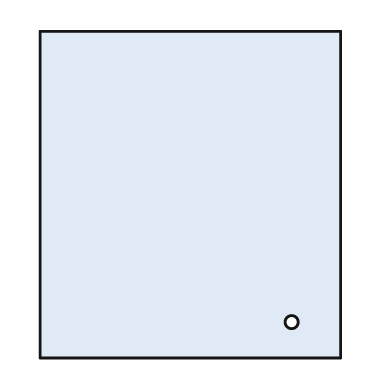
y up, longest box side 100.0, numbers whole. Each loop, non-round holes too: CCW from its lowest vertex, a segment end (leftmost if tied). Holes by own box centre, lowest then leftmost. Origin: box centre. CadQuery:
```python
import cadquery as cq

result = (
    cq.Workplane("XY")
    .moveTo(-46.0, -50.0)
    .lineTo(46.0, -50.0)
    .lineTo(46.0, 50.0)
    .lineTo(-46.0, 50.0)
    .close()
    .moveTo(31.0, -39.0)
    .circle(2.0)
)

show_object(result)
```